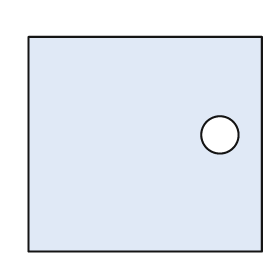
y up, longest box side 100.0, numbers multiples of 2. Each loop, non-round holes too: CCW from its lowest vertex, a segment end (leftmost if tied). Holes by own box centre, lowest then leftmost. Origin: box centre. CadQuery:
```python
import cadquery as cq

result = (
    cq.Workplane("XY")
    .moveTo(-50.0, -46.0)
    .lineTo(50.0, -46.0)
    .lineTo(50.0, 46.0)
    .lineTo(-50.0, 46.0)
    .close()
    .moveTo(32.0, 4.0)
    .circle(8.0)
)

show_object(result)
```